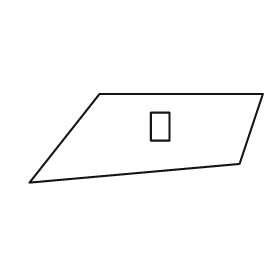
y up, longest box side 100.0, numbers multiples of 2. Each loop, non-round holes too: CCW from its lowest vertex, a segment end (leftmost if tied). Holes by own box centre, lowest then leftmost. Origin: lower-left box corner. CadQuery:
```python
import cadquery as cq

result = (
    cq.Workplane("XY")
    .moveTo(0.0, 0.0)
    .lineTo(90.0, 8.0)
    .lineTo(100.0, 38.0)
    .lineTo(30.0, 38.0)
    .close()
    .moveTo(52.0, 18.0)
    .lineTo(60.0, 18.0)
    .lineTo(60.0, 30.0)
    .lineTo(52.0, 30.0)
    .close()
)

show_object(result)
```